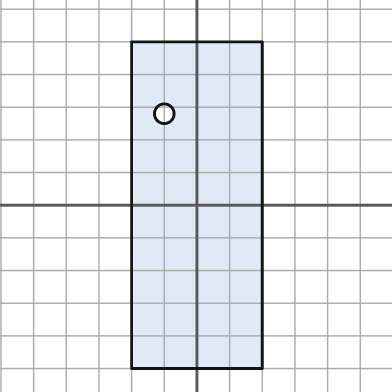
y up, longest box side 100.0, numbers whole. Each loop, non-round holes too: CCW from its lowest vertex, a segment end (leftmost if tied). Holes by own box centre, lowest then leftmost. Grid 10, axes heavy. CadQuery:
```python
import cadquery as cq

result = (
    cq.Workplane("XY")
    .moveTo(-20.0, -50.0)
    .lineTo(20.0, -50.0)
    .lineTo(20.0, 50.0)
    .lineTo(-20.0, 50.0)
    .close()
    .moveTo(-10.0, 28.0)
    .circle(3.0)
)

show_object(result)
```